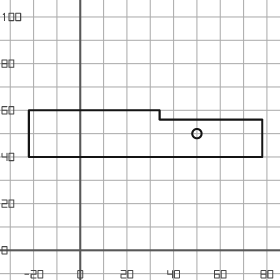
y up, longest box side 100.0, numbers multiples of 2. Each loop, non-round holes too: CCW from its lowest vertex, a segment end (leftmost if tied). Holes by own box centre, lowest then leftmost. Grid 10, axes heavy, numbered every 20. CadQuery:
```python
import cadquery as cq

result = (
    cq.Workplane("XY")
    .moveTo(-22.0, 40.0)
    .lineTo(78.0, 40.0)
    .lineTo(78.0, 56.0)
    .lineTo(34.0, 56.0)
    .lineTo(34.0, 60.0)
    .lineTo(-22.0, 60.0)
    .close()
    .moveTo(50.0, 50.0)
    .circle(2.0)
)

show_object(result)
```